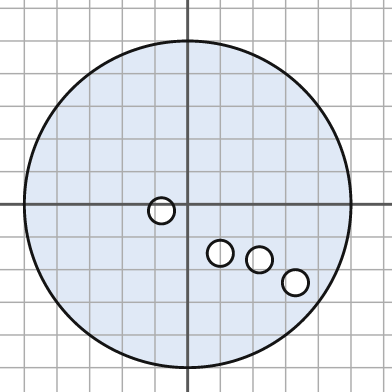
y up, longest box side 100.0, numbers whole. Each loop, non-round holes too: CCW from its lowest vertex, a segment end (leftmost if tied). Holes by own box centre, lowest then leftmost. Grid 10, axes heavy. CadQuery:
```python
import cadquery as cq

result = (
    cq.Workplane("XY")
    .moveTo(0.0, 0.0)
    .circle(50.0)
    .moveTo(33.0, -24.0)
    .circle(4.0)
    .moveTo(22.0, -17.0)
    .circle(4.0)
    .moveTo(10.0, -15.0)
    .circle(4.0)
    .moveTo(-8.0, -2.0)
    .circle(4.0)
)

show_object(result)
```